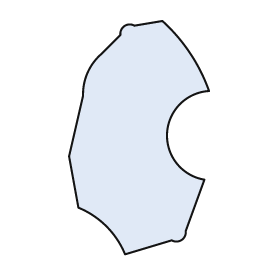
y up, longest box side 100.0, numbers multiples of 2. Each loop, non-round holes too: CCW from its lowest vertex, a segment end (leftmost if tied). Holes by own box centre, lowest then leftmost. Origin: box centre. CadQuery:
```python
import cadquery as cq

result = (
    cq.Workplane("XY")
    .moveTo(-6.0, -50.0)
    .lineTo(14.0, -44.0)
    .threePointArc((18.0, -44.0), (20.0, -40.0))
    .lineTo(28.0, -18.0)
    .threePointArc((12.0, 2.0), (30.0, 20.0))
    .threePointArc((22.0, 36.0), (10.0, 50.0))
    .lineTo(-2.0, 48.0)
    .threePointArc((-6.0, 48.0), (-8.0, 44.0))
    .lineTo(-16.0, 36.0)
    .threePointArc((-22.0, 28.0), (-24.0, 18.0))
    .lineTo(-30.0, -8.0)
    .lineTo(-26.0, -30.0)
    .threePointArc((-14.0, -38.0), (-6.0, -50.0))
    .close()
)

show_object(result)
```